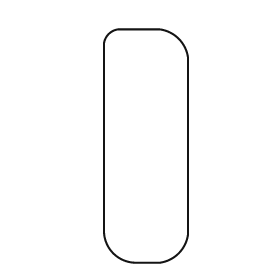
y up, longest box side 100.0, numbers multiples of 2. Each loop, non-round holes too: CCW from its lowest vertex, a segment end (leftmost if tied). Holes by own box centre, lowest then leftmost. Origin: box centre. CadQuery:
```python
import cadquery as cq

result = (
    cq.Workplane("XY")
    .moveTo(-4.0, -50.0)
    .lineTo(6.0, -50.0)
    .threePointArc((14.0, -46.0), (18.0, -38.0))
    .lineTo(18.0, 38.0)
    .threePointArc((14.0, 46.0), (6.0, 50.0))
    .lineTo(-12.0, 50.0)
    .threePointArc((-16.0, 48.0), (-18.0, 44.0))
    .lineTo(-18.0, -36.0)
    .threePointArc((-14.0, -46.0), (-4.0, -50.0))
    .close()
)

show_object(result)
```